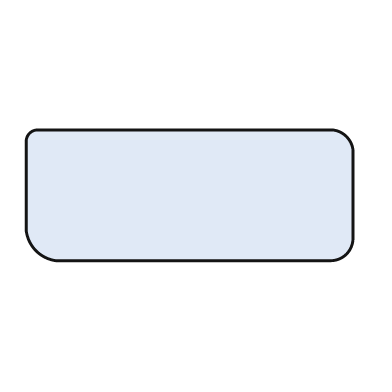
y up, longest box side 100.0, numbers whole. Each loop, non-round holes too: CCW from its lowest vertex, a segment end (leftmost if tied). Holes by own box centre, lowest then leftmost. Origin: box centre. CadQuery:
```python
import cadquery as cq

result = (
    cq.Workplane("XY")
    .moveTo(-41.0, -20.0)
    .lineTo(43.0, -20.0)
    .threePointArc((48.0, -18.0), (50.0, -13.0))
    .lineTo(50.0, 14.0)
    .threePointArc((48.0, 18.0), (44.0, 20.0))
    .lineTo(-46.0, 20.0)
    .threePointArc((-49.0, 19.0), (-50.0, 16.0))
    .lineTo(-50.0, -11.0)
    .threePointArc((-47.0, -17.0), (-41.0, -20.0))
    .close()
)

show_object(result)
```